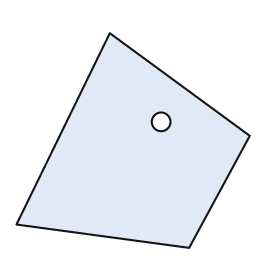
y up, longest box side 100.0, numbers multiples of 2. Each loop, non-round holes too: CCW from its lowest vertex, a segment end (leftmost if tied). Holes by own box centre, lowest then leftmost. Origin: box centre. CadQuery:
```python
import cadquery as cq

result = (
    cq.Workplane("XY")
    .moveTo(24.0, -46.0)
    .lineTo(50.0, 2.0)
    .lineTo(-10.0, 46.0)
    .lineTo(-50.0, -36.0)
    .close()
    .moveTo(12.0, 8.0)
    .circle(4.0)
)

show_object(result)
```